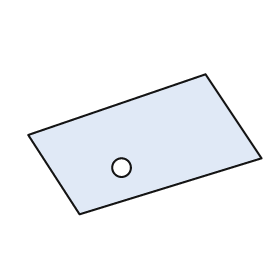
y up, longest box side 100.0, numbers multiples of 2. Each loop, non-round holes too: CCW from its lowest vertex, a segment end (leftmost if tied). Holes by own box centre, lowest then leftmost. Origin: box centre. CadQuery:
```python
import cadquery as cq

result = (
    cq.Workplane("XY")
    .moveTo(-28.0, -30.0)
    .lineTo(50.0, -6.0)
    .lineTo(26.0, 30.0)
    .lineTo(-50.0, 4.0)
    .close()
    .moveTo(-10.0, -10.0)
    .circle(4.0)
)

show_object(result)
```